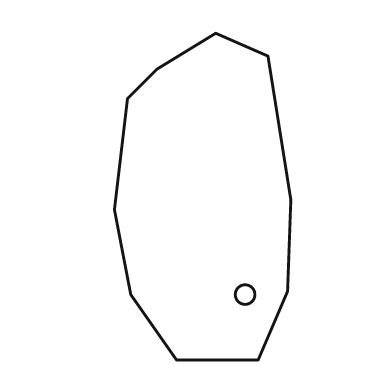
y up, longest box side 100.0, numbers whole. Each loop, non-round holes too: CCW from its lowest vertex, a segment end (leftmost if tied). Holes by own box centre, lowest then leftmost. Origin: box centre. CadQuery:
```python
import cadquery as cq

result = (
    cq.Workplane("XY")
    .moveTo(-8.0, -50.0)
    .lineTo(17.0, -50.0)
    .lineTo(26.0, -29.0)
    .lineTo(27.0, -1.0)
    .lineTo(20.0, 43.0)
    .lineTo(4.0, 50.0)
    .lineTo(-14.0, 39.0)
    .lineTo(-23.0, 30.0)
    .lineTo(-27.0, -4.0)
    .lineTo(-22.0, -30.0)
    .close()
    .moveTo(13.0, -30.0)
    .circle(3.0)
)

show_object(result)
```